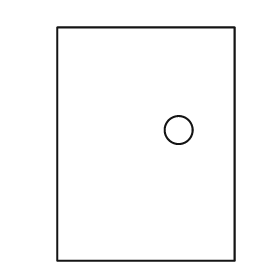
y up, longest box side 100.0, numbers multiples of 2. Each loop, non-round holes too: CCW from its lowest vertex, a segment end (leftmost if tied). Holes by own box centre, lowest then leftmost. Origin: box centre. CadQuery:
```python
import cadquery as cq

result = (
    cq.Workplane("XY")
    .moveTo(-38.0, -50.0)
    .lineTo(38.0, -50.0)
    .lineTo(38.0, 50.0)
    .lineTo(-38.0, 50.0)
    .close()
    .moveTo(14.0, 6.0)
    .circle(6.0)
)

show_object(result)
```